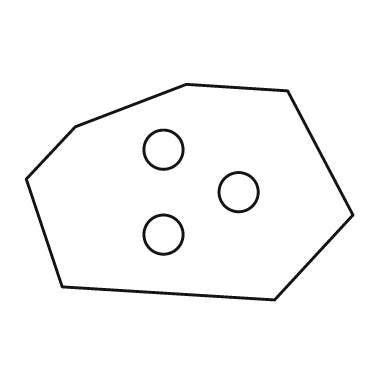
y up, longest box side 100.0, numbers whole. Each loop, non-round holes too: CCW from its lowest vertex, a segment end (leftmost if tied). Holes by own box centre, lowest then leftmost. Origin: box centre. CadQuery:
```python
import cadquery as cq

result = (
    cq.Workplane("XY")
    .moveTo(26.0, -33.0)
    .lineTo(50.0, -7.0)
    .lineTo(30.0, 31.0)
    .lineTo(-1.0, 33.0)
    .lineTo(-35.0, 20.0)
    .lineTo(-50.0, 4.0)
    .lineTo(-39.0, -29.0)
    .close()
    .moveTo(-8.0, -13.0)
    .circle(6.0)
    .moveTo(15.0, 0.0)
    .circle(6.0)
    .moveTo(-8.0, 13.0)
    .circle(6.0)
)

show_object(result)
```